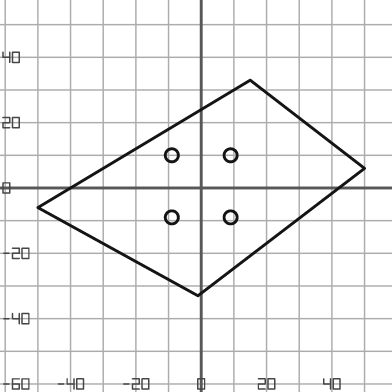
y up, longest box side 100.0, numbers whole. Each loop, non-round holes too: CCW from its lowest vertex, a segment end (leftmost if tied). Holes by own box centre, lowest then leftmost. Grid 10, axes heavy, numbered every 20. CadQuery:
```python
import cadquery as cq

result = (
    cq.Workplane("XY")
    .moveTo(-1.0, -33.0)
    .lineTo(50.0, 6.0)
    .lineTo(15.0, 33.0)
    .lineTo(-50.0, -6.0)
    .close()
    .moveTo(-9.0, -9.0)
    .circle(2.0)
    .moveTo(9.0, -9.0)
    .circle(2.0)
    .moveTo(-9.0, 10.0)
    .circle(2.0)
    .moveTo(9.0, 10.0)
    .circle(2.0)
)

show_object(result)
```